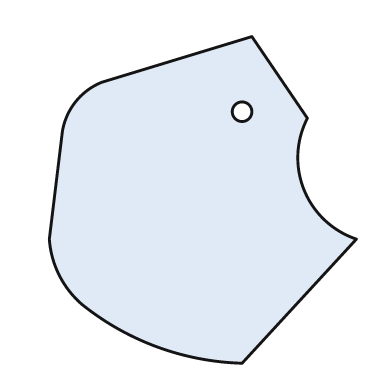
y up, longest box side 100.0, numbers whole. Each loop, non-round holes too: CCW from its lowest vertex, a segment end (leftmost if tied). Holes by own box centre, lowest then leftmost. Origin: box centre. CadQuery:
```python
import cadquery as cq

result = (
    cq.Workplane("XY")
    .moveTo(12.0, -50.0)
    .lineTo(47.0, -12.0)
    .threePointArc((31.0, 3.0), (32.0, 25.0))
    .lineTo(15.0, 50.0)
    .lineTo(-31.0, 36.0)
    .threePointArc((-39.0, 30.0), (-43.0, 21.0))
    .lineTo(-47.0, -12.0)
    .threePointArc((-44.0, -23.0), (-37.0, -32.0))
    .threePointArc((-14.0, -45.0), (12.0, -50.0))
    .close()
    .moveTo(12.0, 27.0)
    .circle(3.0)
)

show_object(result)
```